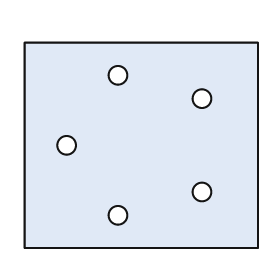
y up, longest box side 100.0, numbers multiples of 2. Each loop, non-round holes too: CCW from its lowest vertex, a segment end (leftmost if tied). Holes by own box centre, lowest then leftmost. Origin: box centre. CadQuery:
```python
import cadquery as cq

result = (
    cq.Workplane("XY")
    .moveTo(-50.0, -44.0)
    .lineTo(50.0, -44.0)
    .lineTo(50.0, 44.0)
    .lineTo(-50.0, 44.0)
    .close()
    .moveTo(-10.0, -30.0)
    .circle(4.0)
    .moveTo(26.0, -20.0)
    .circle(4.0)
    .moveTo(-32.0, 0.0)
    .circle(4.0)
    .moveTo(26.0, 20.0)
    .circle(4.0)
    .moveTo(-10.0, 30.0)
    .circle(4.0)
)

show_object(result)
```